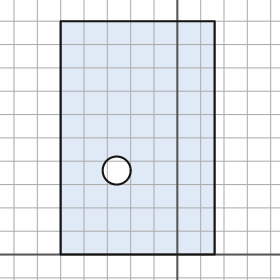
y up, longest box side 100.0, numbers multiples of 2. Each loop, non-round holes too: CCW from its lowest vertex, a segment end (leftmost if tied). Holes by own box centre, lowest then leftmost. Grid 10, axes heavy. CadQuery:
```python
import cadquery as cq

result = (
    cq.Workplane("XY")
    .moveTo(-50.0, 0.0)
    .lineTo(16.0, 0.0)
    .lineTo(16.0, 100.0)
    .lineTo(-50.0, 100.0)
    .close()
    .moveTo(-26.0, 36.0)
    .circle(6.0)
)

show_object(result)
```